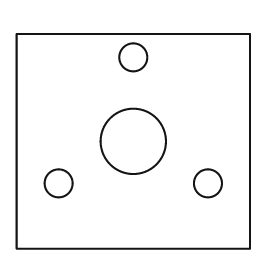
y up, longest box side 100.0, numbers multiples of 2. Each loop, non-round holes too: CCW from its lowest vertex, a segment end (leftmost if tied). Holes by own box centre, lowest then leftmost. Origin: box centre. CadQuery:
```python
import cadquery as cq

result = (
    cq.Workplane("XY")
    .moveTo(-50.0, -46.0)
    .lineTo(50.0, -46.0)
    .lineTo(50.0, 46.0)
    .lineTo(-50.0, 46.0)
    .close()
    .moveTo(-32.0, -18.0)
    .circle(6.0)
    .moveTo(32.0, -18.0)
    .circle(6.0)
    .moveTo(0.0, 0.0)
    .circle(14.0)
    .moveTo(0.0, 36.0)
    .circle(6.0)
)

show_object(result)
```